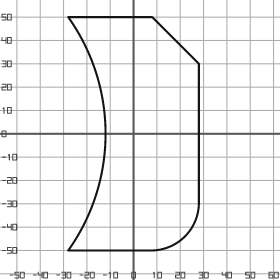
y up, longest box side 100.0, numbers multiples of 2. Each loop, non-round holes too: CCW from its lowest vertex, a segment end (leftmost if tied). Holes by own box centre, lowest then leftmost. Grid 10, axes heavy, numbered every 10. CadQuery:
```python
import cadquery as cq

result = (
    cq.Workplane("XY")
    .moveTo(-28.0, -50.0)
    .lineTo(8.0, -50.0)
    .threePointArc((22.0, -44.0), (28.0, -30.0))
    .lineTo(28.0, 30.0)
    .lineTo(8.0, 50.0)
    .lineTo(-28.0, 50.0)
    .threePointArc((-12.0, 0.0), (-28.0, -50.0))
    .close()
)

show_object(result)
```